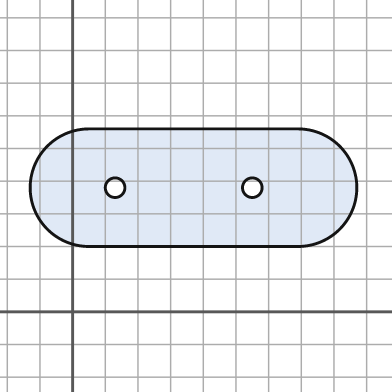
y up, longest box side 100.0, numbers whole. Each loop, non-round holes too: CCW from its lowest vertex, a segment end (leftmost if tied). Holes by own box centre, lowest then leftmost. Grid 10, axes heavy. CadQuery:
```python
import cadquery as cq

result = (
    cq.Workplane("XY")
    .moveTo(5.0, 20.0)
    .lineTo(69.0, 20.0)
    .threePointArc((87.0, 38.0), (69.0, 56.0))
    .lineTo(5.0, 56.0)
    .threePointArc((-13.0, 38.0), (5.0, 20.0))
    .close()
    .moveTo(13.0, 38.0)
    .circle(3.0)
    .moveTo(55.0, 38.0)
    .circle(3.0)
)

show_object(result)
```